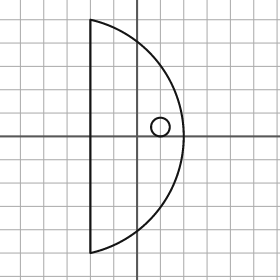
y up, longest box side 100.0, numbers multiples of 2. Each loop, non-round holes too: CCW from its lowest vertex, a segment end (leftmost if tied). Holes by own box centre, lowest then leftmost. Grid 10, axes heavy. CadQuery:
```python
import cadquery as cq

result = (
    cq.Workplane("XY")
    .moveTo(-20.0, -50.0)
    .threePointArc((20.0, 0.0), (-20.0, 50.0))
    .close()
    .moveTo(10.0, 4.0)
    .circle(4.0)
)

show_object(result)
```